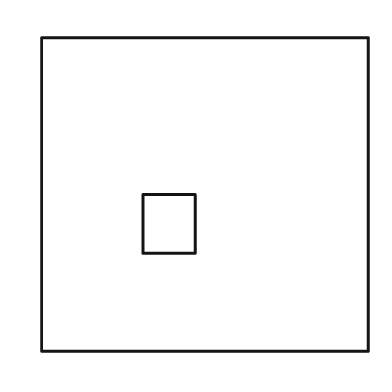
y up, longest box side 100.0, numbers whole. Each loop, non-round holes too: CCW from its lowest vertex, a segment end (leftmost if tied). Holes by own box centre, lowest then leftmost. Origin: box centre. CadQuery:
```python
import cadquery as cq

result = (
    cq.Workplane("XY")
    .moveTo(-50.0, -48.0)
    .lineTo(50.0, -48.0)
    .lineTo(50.0, 48.0)
    .lineTo(-50.0, 48.0)
    .close()
    .moveTo(-19.0, -18.0)
    .lineTo(-3.0, -18.0)
    .lineTo(-3.0, 0.0)
    .lineTo(-19.0, 0.0)
    .close()
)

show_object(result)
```